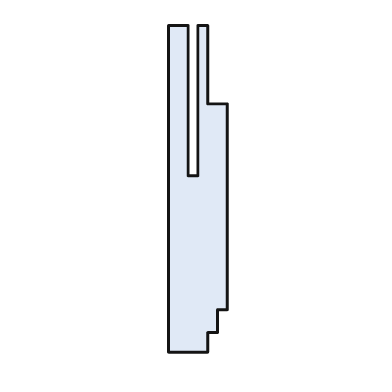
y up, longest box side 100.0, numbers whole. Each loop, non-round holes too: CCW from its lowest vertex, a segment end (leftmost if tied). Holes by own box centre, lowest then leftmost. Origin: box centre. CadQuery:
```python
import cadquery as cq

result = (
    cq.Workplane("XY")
    .moveTo(-9.0, -50.0)
    .lineTo(3.0, -50.0)
    .lineTo(3.0, -44.0)
    .lineTo(6.0, -44.0)
    .lineTo(6.0, -37.0)
    .lineTo(9.0, -37.0)
    .lineTo(9.0, 26.0)
    .lineTo(3.0, 26.0)
    .lineTo(3.0, 50.0)
    .lineTo(0.0, 50.0)
    .lineTo(0.0, 4.0)
    .lineTo(-3.0, 4.0)
    .lineTo(-3.0, 50.0)
    .lineTo(-9.0, 50.0)
    .close()
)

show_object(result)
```